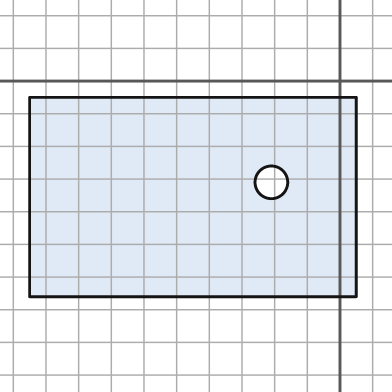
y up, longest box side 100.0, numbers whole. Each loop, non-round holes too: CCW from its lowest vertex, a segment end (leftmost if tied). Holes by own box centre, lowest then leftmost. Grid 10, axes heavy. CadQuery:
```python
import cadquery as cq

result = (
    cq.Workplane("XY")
    .moveTo(-95.0, -66.0)
    .lineTo(5.0, -66.0)
    .lineTo(5.0, -5.0)
    .lineTo(-95.0, -5.0)
    .close()
    .moveTo(-21.0, -31.0)
    .circle(5.0)
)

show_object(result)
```